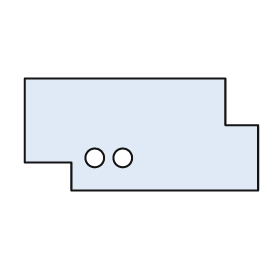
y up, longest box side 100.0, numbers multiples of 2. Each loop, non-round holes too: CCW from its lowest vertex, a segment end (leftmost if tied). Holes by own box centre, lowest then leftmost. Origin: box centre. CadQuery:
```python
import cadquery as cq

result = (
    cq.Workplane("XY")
    .moveTo(-30.0, -24.0)
    .lineTo(50.0, -24.0)
    .lineTo(50.0, 4.0)
    .lineTo(36.0, 4.0)
    .lineTo(36.0, 24.0)
    .lineTo(-50.0, 24.0)
    .lineTo(-50.0, -12.0)
    .lineTo(-30.0, -12.0)
    .close()
    .moveTo(-20.0, -10.0)
    .circle(4.0)
    .moveTo(-8.0, -10.0)
    .circle(4.0)
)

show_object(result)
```